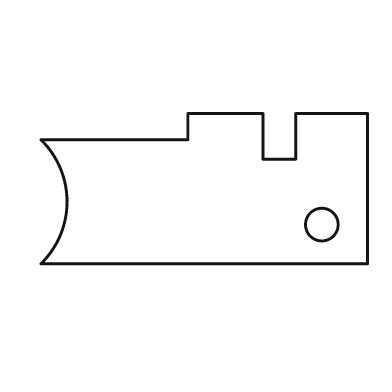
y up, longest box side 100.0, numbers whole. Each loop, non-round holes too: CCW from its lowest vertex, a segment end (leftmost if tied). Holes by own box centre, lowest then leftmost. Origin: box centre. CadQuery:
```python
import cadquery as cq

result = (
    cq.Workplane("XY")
    .moveTo(-50.0, -23.0)
    .lineTo(50.0, -23.0)
    .lineTo(50.0, 23.0)
    .lineTo(28.0, 23.0)
    .lineTo(28.0, 9.0)
    .lineTo(18.0, 9.0)
    .lineTo(18.0, 23.0)
    .lineTo(-5.0, 23.0)
    .lineTo(-5.0, 15.0)
    .lineTo(-50.0, 15.0)
    .threePointArc((-42.0, -4.0), (-50.0, -23.0))
    .close()
    .moveTo(36.0, -11.0)
    .circle(5.0)
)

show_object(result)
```